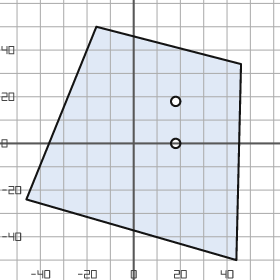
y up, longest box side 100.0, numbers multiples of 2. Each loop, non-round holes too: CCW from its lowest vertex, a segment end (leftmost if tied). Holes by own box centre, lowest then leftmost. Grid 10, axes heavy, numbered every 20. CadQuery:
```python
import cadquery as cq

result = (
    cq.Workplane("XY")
    .moveTo(44.0, -50.0)
    .lineTo(46.0, 34.0)
    .lineTo(-16.0, 50.0)
    .lineTo(-46.0, -24.0)
    .close()
    .moveTo(18.0, 0.0)
    .circle(2.0)
    .moveTo(18.0, 18.0)
    .circle(2.0)
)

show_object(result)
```